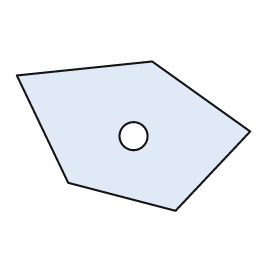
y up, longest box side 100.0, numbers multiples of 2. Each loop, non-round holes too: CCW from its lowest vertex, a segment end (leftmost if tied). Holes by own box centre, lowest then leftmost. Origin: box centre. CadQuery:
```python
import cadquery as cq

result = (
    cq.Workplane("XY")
    .moveTo(18.0, -32.0)
    .lineTo(50.0, 2.0)
    .lineTo(8.0, 32.0)
    .lineTo(-50.0, 26.0)
    .lineTo(-28.0, -20.0)
    .close()
    .moveTo(0.0, 0.0)
    .circle(6.0)
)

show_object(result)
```